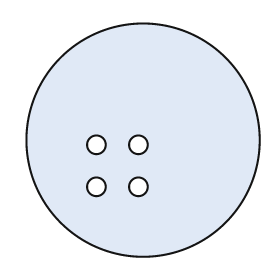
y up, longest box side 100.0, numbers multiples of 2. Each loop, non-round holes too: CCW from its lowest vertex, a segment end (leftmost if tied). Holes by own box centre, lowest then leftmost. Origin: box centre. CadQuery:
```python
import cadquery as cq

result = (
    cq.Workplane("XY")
    .moveTo(0.0, 0.0)
    .circle(50.0)
    .moveTo(-20.0, -20.0)
    .circle(4.0)
    .moveTo(-2.0, -20.0)
    .circle(4.0)
    .moveTo(-20.0, -2.0)
    .circle(4.0)
    .moveTo(-2.0, -2.0)
    .circle(4.0)
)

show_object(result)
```